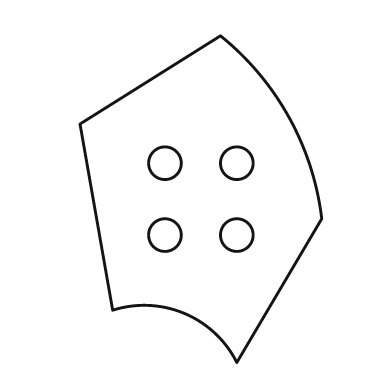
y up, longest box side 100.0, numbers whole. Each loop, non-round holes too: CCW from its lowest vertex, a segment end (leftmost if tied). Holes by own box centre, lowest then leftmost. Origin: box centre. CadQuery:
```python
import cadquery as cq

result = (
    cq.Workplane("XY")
    .moveTo(11.0, -50.0)
    .lineTo(37.0, -6.0)
    .threePointArc((27.0, 25.0), (6.0, 50.0))
    .lineTo(-37.0, 23.0)
    .lineTo(-27.0, -34.0)
    .threePointArc((-5.0, -35.0), (11.0, -50.0))
    .close()
    .moveTo(-11.0, -11.0)
    .circle(5.0)
    .moveTo(11.0, -11.0)
    .circle(5.0)
    .moveTo(-11.0, 11.0)
    .circle(5.0)
    .moveTo(11.0, 11.0)
    .circle(5.0)
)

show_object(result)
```